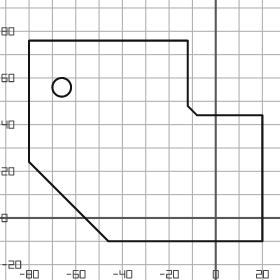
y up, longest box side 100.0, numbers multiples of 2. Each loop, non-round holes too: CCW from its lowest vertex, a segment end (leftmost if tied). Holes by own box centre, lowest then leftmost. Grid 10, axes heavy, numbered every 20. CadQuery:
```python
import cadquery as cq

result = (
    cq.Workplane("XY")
    .moveTo(-46.0, -10.0)
    .lineTo(20.0, -10.0)
    .lineTo(20.0, 44.0)
    .lineTo(-8.0, 44.0)
    .lineTo(-12.0, 48.0)
    .lineTo(-12.0, 76.0)
    .lineTo(-80.0, 76.0)
    .lineTo(-80.0, 24.0)
    .close()
    .moveTo(-66.0, 56.0)
    .circle(4.0)
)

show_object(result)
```